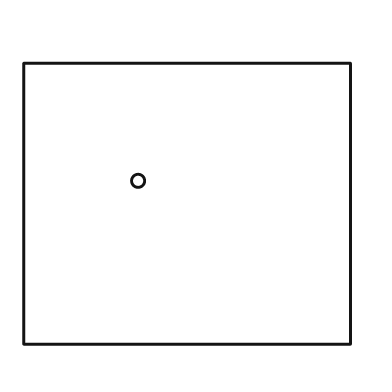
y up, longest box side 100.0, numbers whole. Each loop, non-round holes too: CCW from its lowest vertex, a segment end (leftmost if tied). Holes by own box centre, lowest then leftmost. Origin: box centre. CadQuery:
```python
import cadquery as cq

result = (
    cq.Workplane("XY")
    .moveTo(-50.0, -43.0)
    .lineTo(50.0, -43.0)
    .lineTo(50.0, 43.0)
    .lineTo(-50.0, 43.0)
    .close()
    .moveTo(-15.0, 7.0)
    .circle(2.0)
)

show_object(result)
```